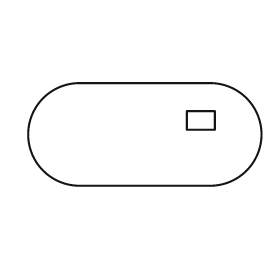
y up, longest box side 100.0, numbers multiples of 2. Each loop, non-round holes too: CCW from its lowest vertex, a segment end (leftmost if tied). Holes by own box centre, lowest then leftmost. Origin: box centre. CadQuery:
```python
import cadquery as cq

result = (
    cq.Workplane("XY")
    .moveTo(-28.0, -22.0)
    .lineTo(28.0, -22.0)
    .threePointArc((50.0, 0.0), (28.0, 22.0))
    .lineTo(-28.0, 22.0)
    .threePointArc((-50.0, 0.0), (-28.0, -22.0))
    .close()
    .moveTo(18.0, 2.0)
    .lineTo(30.0, 2.0)
    .lineTo(30.0, 10.0)
    .lineTo(18.0, 10.0)
    .close()
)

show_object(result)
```